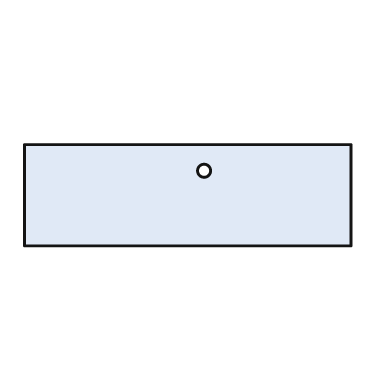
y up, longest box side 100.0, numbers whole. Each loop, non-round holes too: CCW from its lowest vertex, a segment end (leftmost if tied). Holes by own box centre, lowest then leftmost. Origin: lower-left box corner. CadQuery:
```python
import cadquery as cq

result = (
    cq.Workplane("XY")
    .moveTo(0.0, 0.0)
    .lineTo(100.0, 0.0)
    .lineTo(100.0, 31.0)
    .lineTo(0.0, 31.0)
    .close()
    .moveTo(55.0, 23.0)
    .circle(2.0)
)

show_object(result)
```